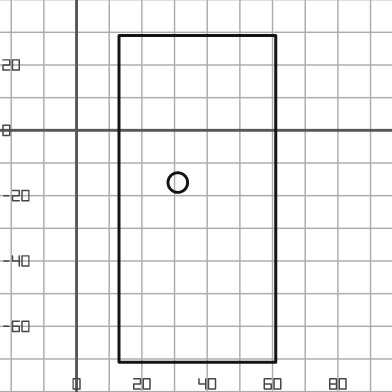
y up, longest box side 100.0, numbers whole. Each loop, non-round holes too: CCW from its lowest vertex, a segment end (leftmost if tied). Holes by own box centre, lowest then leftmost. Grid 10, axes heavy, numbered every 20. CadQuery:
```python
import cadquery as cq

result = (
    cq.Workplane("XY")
    .moveTo(13.0, -71.0)
    .lineTo(61.0, -71.0)
    .lineTo(61.0, 29.0)
    .lineTo(13.0, 29.0)
    .close()
    .moveTo(31.0, -16.0)
    .circle(3.0)
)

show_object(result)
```